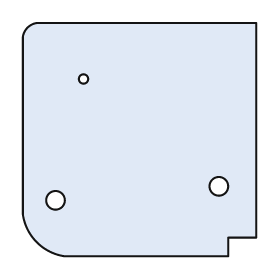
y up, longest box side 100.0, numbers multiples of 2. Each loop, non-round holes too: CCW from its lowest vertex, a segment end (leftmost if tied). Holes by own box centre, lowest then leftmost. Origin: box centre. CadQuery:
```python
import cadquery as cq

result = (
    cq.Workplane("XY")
    .moveTo(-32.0, -50.0)
    .lineTo(38.0, -50.0)
    .lineTo(38.0, -42.0)
    .lineTo(50.0, -42.0)
    .lineTo(50.0, 50.0)
    .lineTo(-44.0, 50.0)
    .threePointArc((-48.0, 48.0), (-50.0, 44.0))
    .lineTo(-50.0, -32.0)
    .threePointArc((-44.0, -44.0), (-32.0, -50.0))
    .close()
    .moveTo(-36.0, -26.0)
    .circle(4.0)
    .moveTo(34.0, -20.0)
    .circle(4.0)
    .moveTo(-24.0, 26.0)
    .circle(2.0)
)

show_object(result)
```